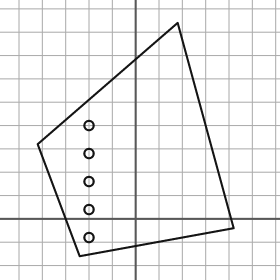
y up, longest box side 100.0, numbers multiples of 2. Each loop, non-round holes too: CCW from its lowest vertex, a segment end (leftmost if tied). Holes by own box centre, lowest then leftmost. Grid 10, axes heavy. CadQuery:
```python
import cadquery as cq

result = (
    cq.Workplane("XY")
    .moveTo(-24.0, -16.0)
    .lineTo(42.0, -4.0)
    .lineTo(18.0, 84.0)
    .lineTo(-42.0, 32.0)
    .close()
    .moveTo(-20.0, -8.0)
    .circle(2.0)
    .moveTo(-20.0, 4.0)
    .circle(2.0)
    .moveTo(-20.0, 16.0)
    .circle(2.0)
    .moveTo(-20.0, 28.0)
    .circle(2.0)
    .moveTo(-20.0, 40.0)
    .circle(2.0)
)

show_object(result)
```